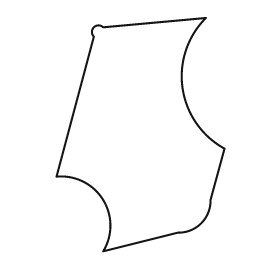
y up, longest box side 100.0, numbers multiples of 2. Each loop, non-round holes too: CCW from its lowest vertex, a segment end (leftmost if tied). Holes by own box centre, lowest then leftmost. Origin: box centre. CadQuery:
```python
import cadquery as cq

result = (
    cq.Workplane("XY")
    .moveTo(-16.0, -50.0)
    .lineTo(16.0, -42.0)
    .threePointArc((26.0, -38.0), (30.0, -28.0))
    .lineTo(36.0, -6.0)
    .threePointArc((18.0, 20.0), (28.0, 50.0))
    .lineTo(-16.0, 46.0)
    .threePointArc((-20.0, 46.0), (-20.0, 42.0))
    .lineTo(-36.0, -18.0)
    .threePointArc((-16.0, -28.0), (-16.0, -50.0))
    .close()
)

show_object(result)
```